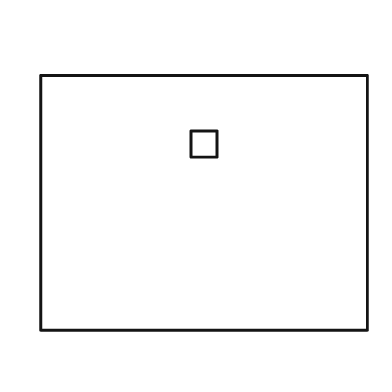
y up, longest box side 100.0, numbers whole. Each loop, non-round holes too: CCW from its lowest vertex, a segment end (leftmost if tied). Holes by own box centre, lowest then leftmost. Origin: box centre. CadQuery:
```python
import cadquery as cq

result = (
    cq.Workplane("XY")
    .moveTo(-50.0, -39.0)
    .lineTo(50.0, -39.0)
    .lineTo(50.0, 39.0)
    .lineTo(-50.0, 39.0)
    .close()
    .moveTo(-4.0, 14.0)
    .lineTo(4.0, 14.0)
    .lineTo(4.0, 22.0)
    .lineTo(-4.0, 22.0)
    .close()
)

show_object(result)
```